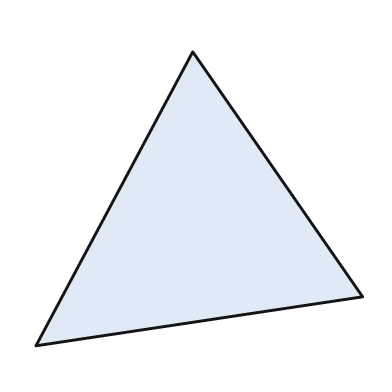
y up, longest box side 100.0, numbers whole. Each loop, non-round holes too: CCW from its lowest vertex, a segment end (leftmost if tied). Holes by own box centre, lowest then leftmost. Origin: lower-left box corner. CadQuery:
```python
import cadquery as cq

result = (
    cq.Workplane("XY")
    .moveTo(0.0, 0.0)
    .lineTo(100.0, 15.0)
    .lineTo(48.0, 90.0)
    .close()
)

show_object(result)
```